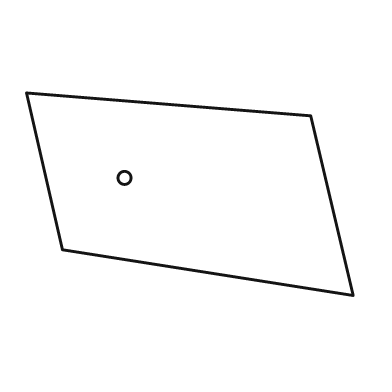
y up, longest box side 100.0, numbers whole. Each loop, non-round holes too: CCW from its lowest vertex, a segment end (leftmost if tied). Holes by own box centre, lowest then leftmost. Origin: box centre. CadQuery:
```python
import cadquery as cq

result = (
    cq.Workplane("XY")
    .moveTo(50.0, -31.0)
    .lineTo(37.0, 24.0)
    .lineTo(-50.0, 31.0)
    .lineTo(-39.0, -17.0)
    .close()
    .moveTo(-20.0, 5.0)
    .circle(2.0)
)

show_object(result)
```